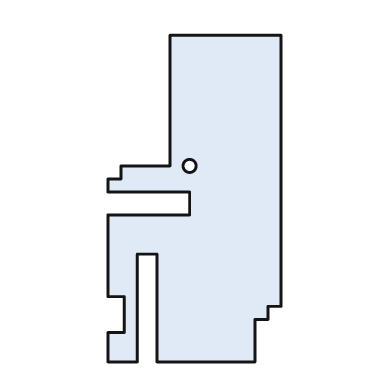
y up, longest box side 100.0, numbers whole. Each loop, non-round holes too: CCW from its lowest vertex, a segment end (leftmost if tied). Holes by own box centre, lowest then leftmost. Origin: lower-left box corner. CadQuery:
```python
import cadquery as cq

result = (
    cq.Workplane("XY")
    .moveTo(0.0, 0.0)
    .lineTo(9.0, 0.0)
    .lineTo(9.0, 33.0)
    .lineTo(15.0, 33.0)
    .lineTo(15.0, 0.0)
    .lineTo(45.0, 0.0)
    .lineTo(45.0, 13.0)
    .lineTo(49.0, 13.0)
    .lineTo(49.0, 17.0)
    .lineTo(53.0, 17.0)
    .lineTo(53.0, 100.0)
    .lineTo(19.0, 100.0)
    .lineTo(19.0, 60.0)
    .lineTo(4.0, 60.0)
    .lineTo(4.0, 56.0)
    .lineTo(0.0, 56.0)
    .lineTo(0.0, 52.0)
    .lineTo(25.0, 52.0)
    .lineTo(25.0, 45.0)
    .lineTo(0.0, 45.0)
    .lineTo(0.0, 20.0)
    .lineTo(5.0, 20.0)
    .lineTo(5.0, 9.0)
    .lineTo(0.0, 9.0)
    .close()
    .moveTo(25.0, 60.0)
    .circle(2.0)
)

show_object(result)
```